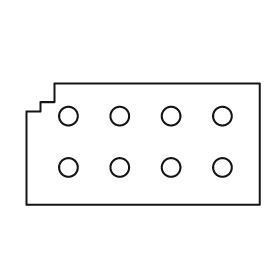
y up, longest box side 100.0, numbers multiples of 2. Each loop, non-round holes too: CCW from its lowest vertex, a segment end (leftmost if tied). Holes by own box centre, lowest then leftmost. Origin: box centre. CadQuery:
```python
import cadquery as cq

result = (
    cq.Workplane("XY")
    .moveTo(-50.0, -26.0)
    .lineTo(50.0, -26.0)
    .lineTo(50.0, 26.0)
    .lineTo(-38.0, 26.0)
    .lineTo(-38.0, 18.0)
    .lineTo(-44.0, 18.0)
    .lineTo(-44.0, 14.0)
    .lineTo(-50.0, 14.0)
    .close()
    .moveTo(-32.0, -10.0)
    .circle(4.0)
    .moveTo(-10.0, -10.0)
    .circle(4.0)
    .moveTo(12.0, -10.0)
    .circle(4.0)
    .moveTo(34.0, -10.0)
    .circle(4.0)
    .moveTo(-32.0, 12.0)
    .circle(4.0)
    .moveTo(-10.0, 12.0)
    .circle(4.0)
    .moveTo(12.0, 12.0)
    .circle(4.0)
    .moveTo(34.0, 12.0)
    .circle(4.0)
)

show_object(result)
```